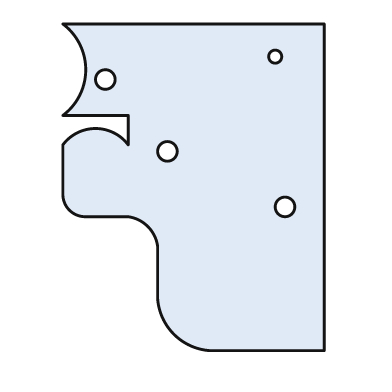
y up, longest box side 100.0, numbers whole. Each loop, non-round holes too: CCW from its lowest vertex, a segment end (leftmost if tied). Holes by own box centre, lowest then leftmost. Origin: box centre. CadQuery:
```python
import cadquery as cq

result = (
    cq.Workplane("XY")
    .moveTo(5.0, -50.0)
    .lineTo(40.0, -50.0)
    .lineTo(40.0, 50.0)
    .lineTo(-40.0, 50.0)
    .threePointArc((-33.0, 36.0), (-40.0, 22.0))
    .lineTo(-20.0, 22.0)
    .lineTo(-20.0, 13.0)
    .threePointArc((-30.0, 18.0), (-40.0, 13.0))
    .lineTo(-40.0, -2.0)
    .threePointArc((-38.0, -7.0), (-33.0, -9.0))
    .lineTo(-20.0, -9.0)
    .threePointArc((-14.0, -12.0), (-11.0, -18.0))
    .lineTo(-11.0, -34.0)
    .threePointArc((-6.0, -45.0), (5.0, -50.0))
    .close()
    .moveTo(28.0, -6.0)
    .circle(3.0)
    .moveTo(-8.0, 11.0)
    .circle(3.0)
    .moveTo(-27.0, 33.0)
    .circle(3.0)
    .moveTo(25.0, 40.0)
    .circle(2.0)
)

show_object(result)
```